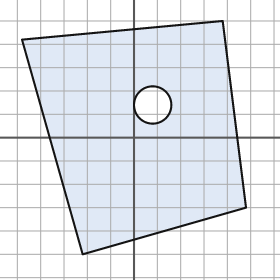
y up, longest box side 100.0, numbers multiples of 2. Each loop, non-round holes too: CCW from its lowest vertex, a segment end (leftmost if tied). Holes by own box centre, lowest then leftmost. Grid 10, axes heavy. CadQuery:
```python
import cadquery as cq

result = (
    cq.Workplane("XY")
    .moveTo(-22.0, -50.0)
    .lineTo(48.0, -30.0)
    .lineTo(38.0, 50.0)
    .lineTo(-48.0, 42.0)
    .close()
    .moveTo(8.0, 14.0)
    .circle(8.0)
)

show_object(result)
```